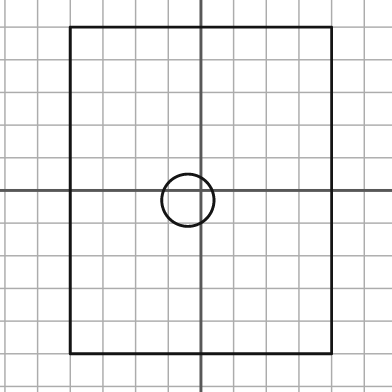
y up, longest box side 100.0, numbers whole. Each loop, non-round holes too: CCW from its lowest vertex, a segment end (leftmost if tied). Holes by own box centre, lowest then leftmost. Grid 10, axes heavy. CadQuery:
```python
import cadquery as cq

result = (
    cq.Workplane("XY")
    .moveTo(-40.0, -50.0)
    .lineTo(40.0, -50.0)
    .lineTo(40.0, 50.0)
    .lineTo(-40.0, 50.0)
    .close()
    .moveTo(-4.0, -3.0)
    .circle(8.0)
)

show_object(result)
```